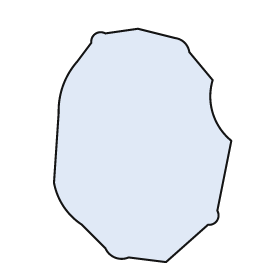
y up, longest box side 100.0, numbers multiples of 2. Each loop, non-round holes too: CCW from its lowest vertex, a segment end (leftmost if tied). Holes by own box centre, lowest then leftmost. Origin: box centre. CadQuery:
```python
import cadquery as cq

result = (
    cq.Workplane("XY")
    .moveTo(10.0, -50.0)
    .lineTo(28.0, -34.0)
    .threePointArc((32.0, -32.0), (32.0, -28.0))
    .lineTo(38.0, 2.0)
    .threePointArc((30.0, 14.0), (30.0, 28.0))
    .lineTo(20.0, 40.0)
    .threePointArc((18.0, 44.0), (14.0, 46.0))
    .lineTo(-2.0, 50.0)
    .lineTo(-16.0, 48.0)
    .threePointArc((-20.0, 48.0), (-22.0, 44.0))
    .lineTo(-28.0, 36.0)
    .threePointArc((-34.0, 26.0), (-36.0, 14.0))
    .lineTo(-38.0, -16.0)
    .threePointArc((-34.0, -26.0), (-26.0, -34.0))
    .lineTo(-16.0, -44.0)
    .threePointArc((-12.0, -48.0), (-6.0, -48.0))
    .close()
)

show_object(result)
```